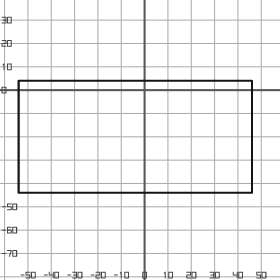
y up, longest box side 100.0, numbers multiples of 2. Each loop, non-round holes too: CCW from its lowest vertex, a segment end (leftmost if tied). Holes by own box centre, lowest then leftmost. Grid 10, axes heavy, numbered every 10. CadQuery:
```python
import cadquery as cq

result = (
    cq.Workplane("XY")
    .moveTo(-54.0, -44.0)
    .lineTo(46.0, -44.0)
    .lineTo(46.0, 4.0)
    .lineTo(-54.0, 4.0)
    .close()
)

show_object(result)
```